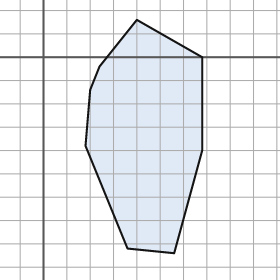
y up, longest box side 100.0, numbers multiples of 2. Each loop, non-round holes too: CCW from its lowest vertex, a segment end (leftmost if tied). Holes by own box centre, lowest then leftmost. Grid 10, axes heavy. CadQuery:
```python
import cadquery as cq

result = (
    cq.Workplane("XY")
    .moveTo(56.0, -84.0)
    .lineTo(68.0, -40.0)
    .lineTo(68.0, 0.0)
    .lineTo(40.0, 16.0)
    .lineTo(24.0, -4.0)
    .lineTo(20.0, -14.0)
    .lineTo(18.0, -38.0)
    .lineTo(36.0, -82.0)
    .close()
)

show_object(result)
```